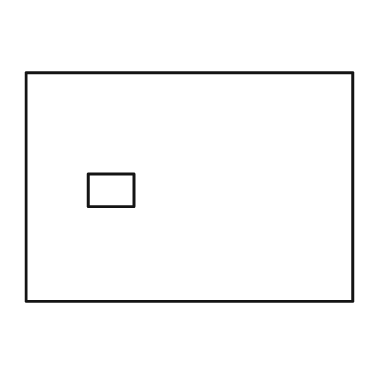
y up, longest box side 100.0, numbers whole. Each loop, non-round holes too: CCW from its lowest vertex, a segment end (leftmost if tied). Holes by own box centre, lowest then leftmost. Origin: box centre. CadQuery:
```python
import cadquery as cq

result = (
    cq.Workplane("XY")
    .moveTo(-50.0, -35.0)
    .lineTo(50.0, -35.0)
    .lineTo(50.0, 35.0)
    .lineTo(-50.0, 35.0)
    .close()
    .moveTo(-31.0, -6.0)
    .lineTo(-17.0, -6.0)
    .lineTo(-17.0, 4.0)
    .lineTo(-31.0, 4.0)
    .close()
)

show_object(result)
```